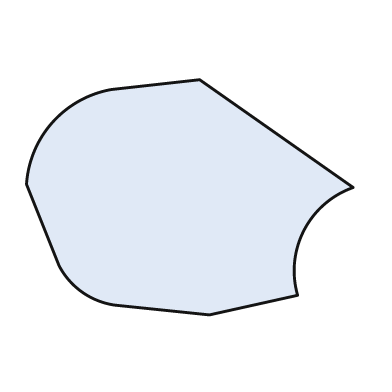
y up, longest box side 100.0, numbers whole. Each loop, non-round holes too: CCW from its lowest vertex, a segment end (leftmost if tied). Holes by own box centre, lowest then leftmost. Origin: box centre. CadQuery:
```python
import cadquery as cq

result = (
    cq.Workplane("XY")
    .moveTo(6.0, -36.0)
    .lineTo(33.0, -30.0)
    .threePointArc((35.0, -10.0), (50.0, 3.0))
    .lineTo(3.0, 36.0)
    .lineTo(-24.0, 33.0)
    .threePointArc((-42.0, 23.0), (-50.0, 4.0))
    .lineTo(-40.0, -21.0)
    .threePointArc((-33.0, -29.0), (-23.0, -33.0))
    .close()
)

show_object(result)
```